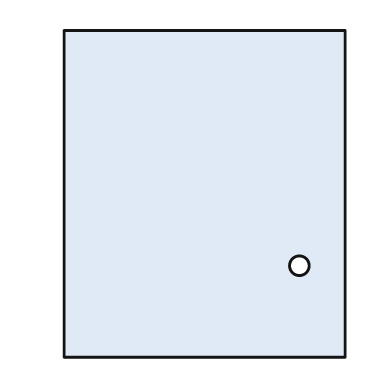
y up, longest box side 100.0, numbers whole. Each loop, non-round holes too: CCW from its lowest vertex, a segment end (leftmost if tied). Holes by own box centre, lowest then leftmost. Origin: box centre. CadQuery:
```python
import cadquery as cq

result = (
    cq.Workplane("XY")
    .moveTo(-43.0, -50.0)
    .lineTo(43.0, -50.0)
    .lineTo(43.0, 50.0)
    .lineTo(-43.0, 50.0)
    .close()
    .moveTo(29.0, -22.0)
    .circle(3.0)
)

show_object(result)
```